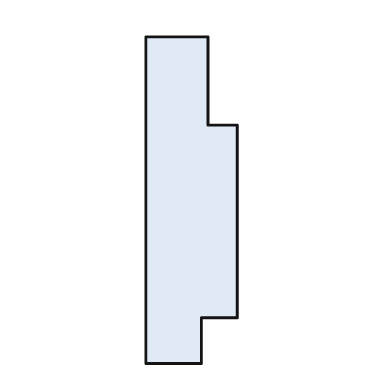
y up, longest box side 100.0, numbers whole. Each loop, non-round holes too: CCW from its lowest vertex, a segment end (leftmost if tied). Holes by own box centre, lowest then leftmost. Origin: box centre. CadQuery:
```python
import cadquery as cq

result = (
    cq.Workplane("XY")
    .moveTo(-14.0, -50.0)
    .lineTo(3.0, -50.0)
    .lineTo(3.0, -36.0)
    .lineTo(14.0, -36.0)
    .lineTo(14.0, 23.0)
    .lineTo(5.0, 23.0)
    .lineTo(5.0, 50.0)
    .lineTo(-14.0, 50.0)
    .close()
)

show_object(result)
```